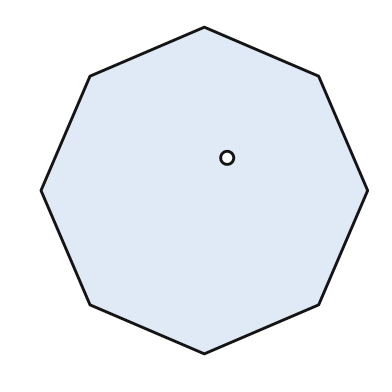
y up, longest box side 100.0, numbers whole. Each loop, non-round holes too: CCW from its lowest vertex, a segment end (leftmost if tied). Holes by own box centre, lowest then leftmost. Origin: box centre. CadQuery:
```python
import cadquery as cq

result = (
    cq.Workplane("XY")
    .moveTo(0.0, -50.0)
    .lineTo(35.0, -35.0)
    .lineTo(50.0, 0.0)
    .lineTo(35.0, 35.0)
    .lineTo(0.0, 50.0)
    .lineTo(-35.0, 35.0)
    .lineTo(-50.0, 0.0)
    .lineTo(-35.0, -35.0)
    .close()
    .moveTo(7.0, 10.0)
    .circle(2.0)
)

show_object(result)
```